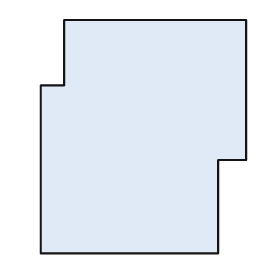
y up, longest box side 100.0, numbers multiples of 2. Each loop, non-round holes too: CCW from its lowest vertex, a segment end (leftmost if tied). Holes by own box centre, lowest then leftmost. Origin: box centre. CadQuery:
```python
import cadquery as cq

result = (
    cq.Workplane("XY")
    .moveTo(-44.0, -50.0)
    .lineTo(32.0, -50.0)
    .lineTo(32.0, -10.0)
    .lineTo(44.0, -10.0)
    .lineTo(44.0, 50.0)
    .lineTo(-34.0, 50.0)
    .lineTo(-34.0, 22.0)
    .lineTo(-44.0, 22.0)
    .close()
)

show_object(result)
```